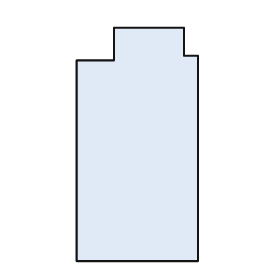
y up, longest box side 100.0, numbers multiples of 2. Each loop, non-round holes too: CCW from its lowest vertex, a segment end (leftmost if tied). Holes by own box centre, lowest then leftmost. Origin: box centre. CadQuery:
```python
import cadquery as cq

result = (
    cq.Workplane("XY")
    .moveTo(-26.0, -50.0)
    .lineTo(26.0, -50.0)
    .lineTo(26.0, 38.0)
    .lineTo(20.0, 38.0)
    .lineTo(20.0, 50.0)
    .lineTo(-10.0, 50.0)
    .lineTo(-10.0, 36.0)
    .lineTo(-26.0, 36.0)
    .close()
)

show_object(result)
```